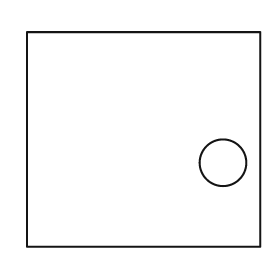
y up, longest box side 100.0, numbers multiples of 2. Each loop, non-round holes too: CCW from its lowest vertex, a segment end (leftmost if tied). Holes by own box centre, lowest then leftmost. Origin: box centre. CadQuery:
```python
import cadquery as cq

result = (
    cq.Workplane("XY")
    .moveTo(-50.0, -46.0)
    .lineTo(50.0, -46.0)
    .lineTo(50.0, 46.0)
    .lineTo(-50.0, 46.0)
    .close()
    .moveTo(34.0, -10.0)
    .circle(10.0)
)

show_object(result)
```